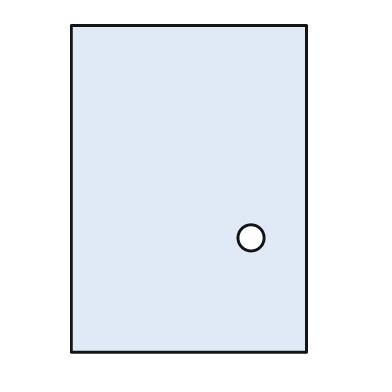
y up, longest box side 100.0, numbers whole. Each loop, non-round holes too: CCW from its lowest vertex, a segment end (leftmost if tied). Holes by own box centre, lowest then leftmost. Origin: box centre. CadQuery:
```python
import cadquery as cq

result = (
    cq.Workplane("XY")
    .moveTo(-36.0, -50.0)
    .lineTo(36.0, -50.0)
    .lineTo(36.0, 50.0)
    .lineTo(-36.0, 50.0)
    .close()
    .moveTo(19.0, -15.0)
    .circle(4.0)
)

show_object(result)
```